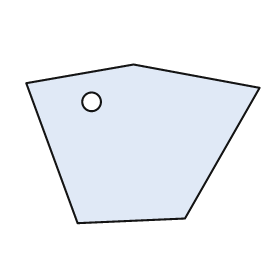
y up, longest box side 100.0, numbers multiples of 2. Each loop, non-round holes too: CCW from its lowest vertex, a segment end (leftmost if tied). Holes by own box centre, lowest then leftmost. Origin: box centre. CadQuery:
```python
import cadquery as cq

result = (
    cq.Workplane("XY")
    .moveTo(-28.0, -34.0)
    .lineTo(18.0, -32.0)
    .lineTo(50.0, 24.0)
    .lineTo(-4.0, 34.0)
    .lineTo(-50.0, 26.0)
    .close()
    .moveTo(-22.0, 18.0)
    .circle(4.0)
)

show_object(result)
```